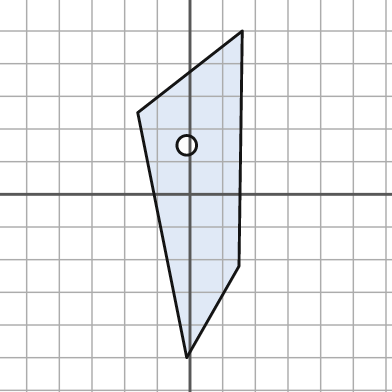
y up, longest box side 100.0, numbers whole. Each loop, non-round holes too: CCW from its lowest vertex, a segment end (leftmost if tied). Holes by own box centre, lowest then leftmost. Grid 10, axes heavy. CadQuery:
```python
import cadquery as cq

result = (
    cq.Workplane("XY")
    .moveTo(-1.0, -50.0)
    .lineTo(15.0, -22.0)
    .lineTo(16.0, 50.0)
    .lineTo(-16.0, 25.0)
    .close()
    .moveTo(-1.0, 15.0)
    .circle(3.0)
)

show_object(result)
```